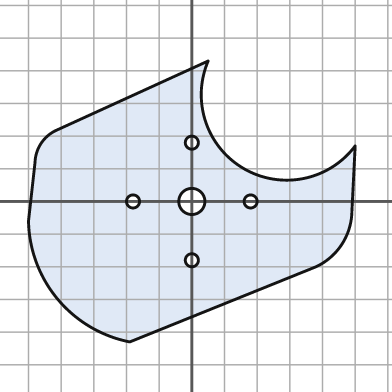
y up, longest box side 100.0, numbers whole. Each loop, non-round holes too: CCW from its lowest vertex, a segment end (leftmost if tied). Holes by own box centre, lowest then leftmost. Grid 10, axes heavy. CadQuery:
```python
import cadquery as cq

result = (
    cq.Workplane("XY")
    .moveTo(-19.0, -43.0)
    .lineTo(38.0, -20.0)
    .threePointArc((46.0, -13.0), (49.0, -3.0))
    .lineTo(50.0, 17.0)
    .threePointArc((16.0, 10.0), (5.0, 43.0))
    .lineTo(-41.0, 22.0)
    .threePointArc((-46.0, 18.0), (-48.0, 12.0))
    .lineTo(-50.0, -6.0)
    .threePointArc((-41.0, -30.0), (-19.0, -43.0))
    .close()
    .moveTo(0.0, -18.0)
    .circle(2.0)
    .moveTo(-18.0, 0.0)
    .circle(2.0)
    .moveTo(0.0, 0.0)
    .circle(4.0)
    .moveTo(18.0, 0.0)
    .circle(2.0)
    .moveTo(0.0, 18.0)
    .circle(2.0)
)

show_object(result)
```